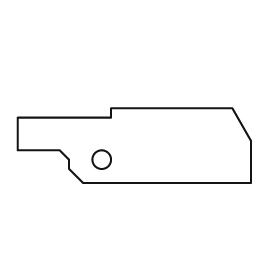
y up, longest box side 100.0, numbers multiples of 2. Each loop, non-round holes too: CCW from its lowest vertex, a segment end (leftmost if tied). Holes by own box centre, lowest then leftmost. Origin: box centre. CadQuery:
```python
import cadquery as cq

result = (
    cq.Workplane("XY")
    .moveTo(-22.0, -16.0)
    .lineTo(50.0, -16.0)
    .lineTo(50.0, 2.0)
    .lineTo(42.0, 16.0)
    .lineTo(-10.0, 16.0)
    .lineTo(-10.0, 12.0)
    .lineTo(-50.0, 12.0)
    .lineTo(-50.0, -2.0)
    .lineTo(-32.0, -2.0)
    .lineTo(-28.0, -6.0)
    .lineTo(-28.0, -10.0)
    .close()
    .moveTo(-14.0, -6.0)
    .circle(4.0)
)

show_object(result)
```